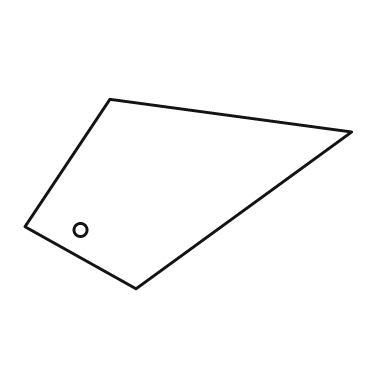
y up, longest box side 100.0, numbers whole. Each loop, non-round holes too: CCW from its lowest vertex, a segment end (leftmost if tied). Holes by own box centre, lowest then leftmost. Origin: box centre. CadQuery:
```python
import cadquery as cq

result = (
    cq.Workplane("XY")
    .moveTo(-16.0, -29.0)
    .lineTo(50.0, 19.0)
    .lineTo(-24.0, 29.0)
    .lineTo(-50.0, -10.0)
    .close()
    .moveTo(-33.0, -11.0)
    .circle(2.0)
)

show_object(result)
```